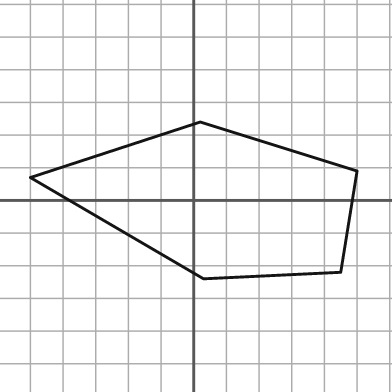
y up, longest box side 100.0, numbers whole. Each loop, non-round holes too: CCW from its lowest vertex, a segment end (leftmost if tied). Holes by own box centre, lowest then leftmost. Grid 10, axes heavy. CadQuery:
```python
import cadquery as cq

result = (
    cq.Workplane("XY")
    .moveTo(3.0, -24.0)
    .lineTo(45.0, -22.0)
    .lineTo(50.0, 9.0)
    .lineTo(2.0, 24.0)
    .lineTo(-50.0, 7.0)
    .close()
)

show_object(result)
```